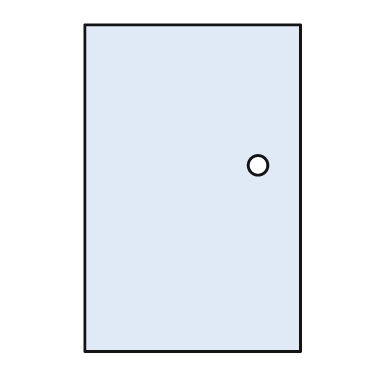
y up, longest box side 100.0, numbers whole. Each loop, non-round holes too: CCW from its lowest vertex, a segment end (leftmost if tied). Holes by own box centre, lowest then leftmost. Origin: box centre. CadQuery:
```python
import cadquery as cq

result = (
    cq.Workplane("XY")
    .moveTo(-33.0, -50.0)
    .lineTo(33.0, -50.0)
    .lineTo(33.0, 50.0)
    .lineTo(-33.0, 50.0)
    .close()
    .moveTo(20.0, 7.0)
    .circle(3.0)
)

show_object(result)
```